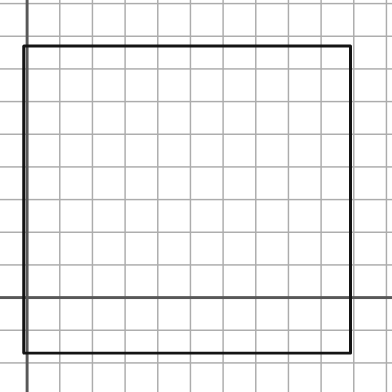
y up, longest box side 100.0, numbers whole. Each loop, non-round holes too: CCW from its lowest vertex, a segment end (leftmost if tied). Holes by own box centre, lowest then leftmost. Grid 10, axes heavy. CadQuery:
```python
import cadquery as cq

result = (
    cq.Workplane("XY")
    .moveTo(-1.0, -17.0)
    .lineTo(99.0, -17.0)
    .lineTo(99.0, 77.0)
    .lineTo(-1.0, 77.0)
    .close()
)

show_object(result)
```